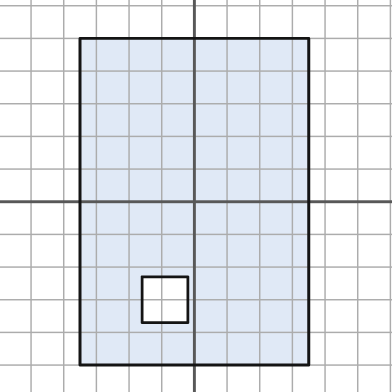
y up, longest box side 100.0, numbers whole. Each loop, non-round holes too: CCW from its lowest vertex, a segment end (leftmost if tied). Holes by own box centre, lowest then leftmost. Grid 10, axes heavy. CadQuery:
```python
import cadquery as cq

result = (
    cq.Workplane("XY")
    .moveTo(-35.0, -50.0)
    .lineTo(35.0, -50.0)
    .lineTo(35.0, 50.0)
    .lineTo(-35.0, 50.0)
    .close()
    .moveTo(-16.0, -37.0)
    .lineTo(-2.0, -37.0)
    .lineTo(-2.0, -23.0)
    .lineTo(-16.0, -23.0)
    .close()
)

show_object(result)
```